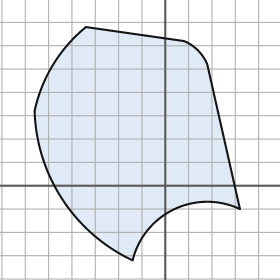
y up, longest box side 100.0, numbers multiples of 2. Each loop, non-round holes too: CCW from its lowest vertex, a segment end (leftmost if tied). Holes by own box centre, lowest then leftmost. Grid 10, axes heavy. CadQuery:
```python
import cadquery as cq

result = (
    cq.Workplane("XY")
    .moveTo(-14.0, -32.0)
    .threePointArc((4.0, -10.0), (32.0, -10.0))
    .lineTo(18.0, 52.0)
    .threePointArc((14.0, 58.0), (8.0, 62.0))
    .lineTo(-34.0, 68.0)
    .threePointArc((-48.0, 52.0), (-56.0, 32.0))
    .threePointArc((-44.0, -6.0), (-14.0, -32.0))
    .close()
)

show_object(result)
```